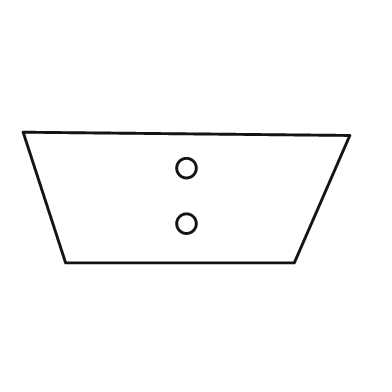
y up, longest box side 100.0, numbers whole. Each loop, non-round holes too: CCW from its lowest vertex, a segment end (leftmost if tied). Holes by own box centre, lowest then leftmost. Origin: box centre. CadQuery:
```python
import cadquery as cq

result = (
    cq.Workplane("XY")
    .moveTo(-37.0, -20.0)
    .lineTo(33.0, -20.0)
    .lineTo(50.0, 19.0)
    .lineTo(-50.0, 20.0)
    .close()
    .moveTo(0.0, -8.0)
    .circle(3.0)
    .moveTo(0.0, 9.0)
    .circle(3.0)
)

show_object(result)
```